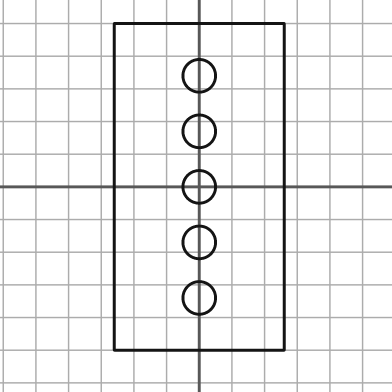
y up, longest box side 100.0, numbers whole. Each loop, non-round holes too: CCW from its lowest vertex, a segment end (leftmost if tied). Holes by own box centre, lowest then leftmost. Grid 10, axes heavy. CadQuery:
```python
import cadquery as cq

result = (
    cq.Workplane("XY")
    .moveTo(-26.0, -50.0)
    .lineTo(26.0, -50.0)
    .lineTo(26.0, 50.0)
    .lineTo(-26.0, 50.0)
    .close()
    .moveTo(0.0, -34.0)
    .circle(5.0)
    .moveTo(0.0, -17.0)
    .circle(5.0)
    .moveTo(0.0, 0.0)
    .circle(5.0)
    .moveTo(0.0, 17.0)
    .circle(5.0)
    .moveTo(0.0, 34.0)
    .circle(5.0)
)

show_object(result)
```